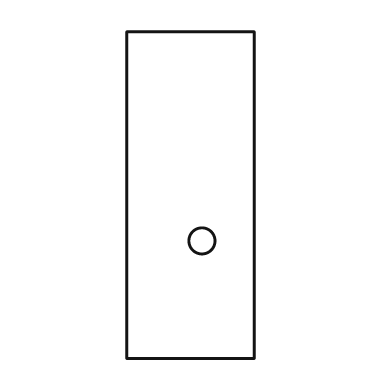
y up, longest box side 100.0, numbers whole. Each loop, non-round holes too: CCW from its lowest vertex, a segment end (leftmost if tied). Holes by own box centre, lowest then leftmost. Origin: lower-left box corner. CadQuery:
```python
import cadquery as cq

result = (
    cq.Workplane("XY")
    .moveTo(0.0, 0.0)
    .lineTo(39.0, 0.0)
    .lineTo(39.0, 100.0)
    .lineTo(0.0, 100.0)
    .close()
    .moveTo(23.0, 36.0)
    .circle(4.0)
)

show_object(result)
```